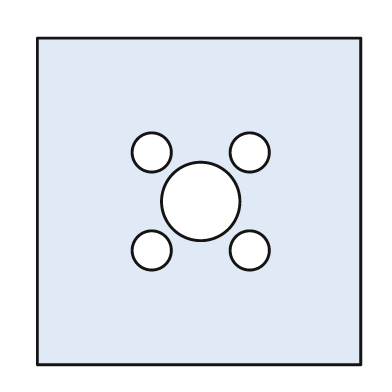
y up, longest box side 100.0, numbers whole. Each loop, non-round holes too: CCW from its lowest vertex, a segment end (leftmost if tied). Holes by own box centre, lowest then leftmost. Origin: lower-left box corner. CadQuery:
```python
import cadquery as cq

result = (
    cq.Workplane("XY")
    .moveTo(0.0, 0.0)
    .lineTo(99.0, 0.0)
    .lineTo(99.0, 100.0)
    .lineTo(0.0, 100.0)
    .close()
    .moveTo(35.0, 35.0)
    .circle(6.0)
    .moveTo(65.0, 35.0)
    .circle(6.0)
    .moveTo(50.0, 50.0)
    .circle(12.0)
    .moveTo(35.0, 65.0)
    .circle(6.0)
    .moveTo(65.0, 65.0)
    .circle(6.0)
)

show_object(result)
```